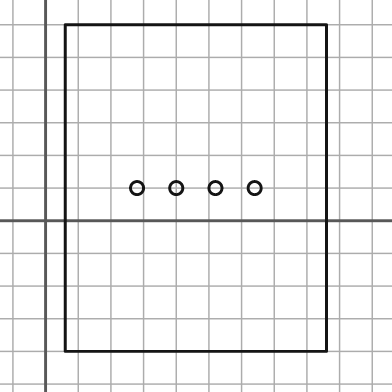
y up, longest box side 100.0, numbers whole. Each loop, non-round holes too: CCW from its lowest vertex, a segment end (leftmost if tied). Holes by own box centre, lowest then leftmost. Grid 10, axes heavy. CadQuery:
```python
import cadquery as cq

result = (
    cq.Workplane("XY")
    .moveTo(6.0, -40.0)
    .lineTo(86.0, -40.0)
    .lineTo(86.0, 60.0)
    .lineTo(6.0, 60.0)
    .close()
    .moveTo(28.0, 10.0)
    .circle(2.0)
    .moveTo(40.0, 10.0)
    .circle(2.0)
    .moveTo(52.0, 10.0)
    .circle(2.0)
    .moveTo(64.0, 10.0)
    .circle(2.0)
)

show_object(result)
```